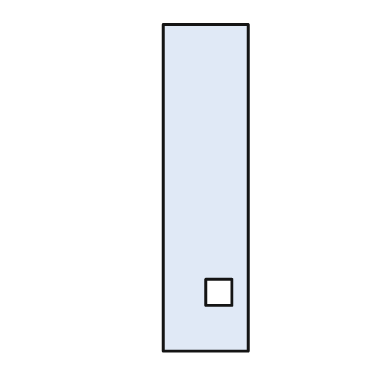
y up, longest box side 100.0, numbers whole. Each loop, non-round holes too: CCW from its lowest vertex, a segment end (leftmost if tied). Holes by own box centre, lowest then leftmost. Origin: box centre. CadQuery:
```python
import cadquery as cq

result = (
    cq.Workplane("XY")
    .moveTo(-13.0, -50.0)
    .lineTo(13.0, -50.0)
    .lineTo(13.0, 50.0)
    .lineTo(-13.0, 50.0)
    .close()
    .moveTo(0.0, -36.0)
    .lineTo(8.0, -36.0)
    .lineTo(8.0, -28.0)
    .lineTo(0.0, -28.0)
    .close()
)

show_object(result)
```